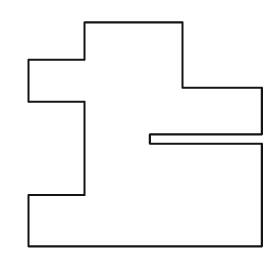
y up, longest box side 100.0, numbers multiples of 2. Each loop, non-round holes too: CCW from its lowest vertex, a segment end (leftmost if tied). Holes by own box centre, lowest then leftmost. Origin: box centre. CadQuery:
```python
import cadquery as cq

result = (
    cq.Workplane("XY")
    .moveTo(-50.0, -48.0)
    .lineTo(50.0, -48.0)
    .lineTo(50.0, -4.0)
    .lineTo(2.0, -4.0)
    .lineTo(2.0, 0.0)
    .lineTo(50.0, 0.0)
    .lineTo(50.0, 20.0)
    .lineTo(16.0, 20.0)
    .lineTo(16.0, 48.0)
    .lineTo(-26.0, 48.0)
    .lineTo(-26.0, 32.0)
    .lineTo(-50.0, 32.0)
    .lineTo(-50.0, 14.0)
    .lineTo(-26.0, 14.0)
    .lineTo(-26.0, -26.0)
    .lineTo(-50.0, -26.0)
    .close()
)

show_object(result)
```